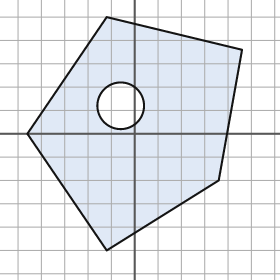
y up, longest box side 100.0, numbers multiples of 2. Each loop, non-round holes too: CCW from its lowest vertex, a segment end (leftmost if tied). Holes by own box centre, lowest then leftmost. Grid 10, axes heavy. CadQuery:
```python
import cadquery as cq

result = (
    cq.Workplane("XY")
    .moveTo(-12.0, -50.0)
    .lineTo(36.0, -20.0)
    .lineTo(46.0, 36.0)
    .lineTo(-12.0, 50.0)
    .lineTo(-46.0, 0.0)
    .close()
    .moveTo(-6.0, 12.0)
    .circle(10.0)
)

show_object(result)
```